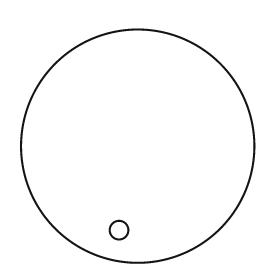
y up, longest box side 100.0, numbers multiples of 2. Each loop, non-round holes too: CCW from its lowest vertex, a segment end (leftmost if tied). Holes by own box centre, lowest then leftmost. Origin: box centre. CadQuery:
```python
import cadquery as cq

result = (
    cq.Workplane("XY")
    .moveTo(0.0, 0.0)
    .circle(50.0)
    .moveTo(-8.0, -36.0)
    .circle(4.0)
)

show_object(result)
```